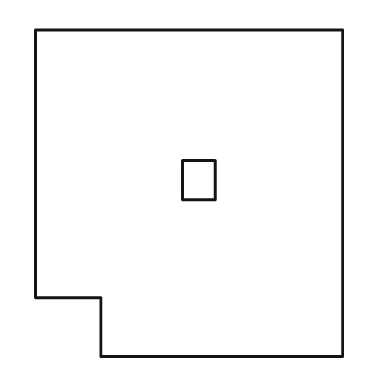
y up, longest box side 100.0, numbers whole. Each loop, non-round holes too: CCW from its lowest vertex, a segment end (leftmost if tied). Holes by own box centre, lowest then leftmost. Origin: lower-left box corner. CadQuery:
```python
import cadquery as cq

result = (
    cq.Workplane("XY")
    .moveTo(20.0, 0.0)
    .lineTo(94.0, 0.0)
    .lineTo(94.0, 100.0)
    .lineTo(0.0, 100.0)
    .lineTo(0.0, 18.0)
    .lineTo(20.0, 18.0)
    .close()
    .moveTo(45.0, 48.0)
    .lineTo(55.0, 48.0)
    .lineTo(55.0, 60.0)
    .lineTo(45.0, 60.0)
    .close()
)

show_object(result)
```